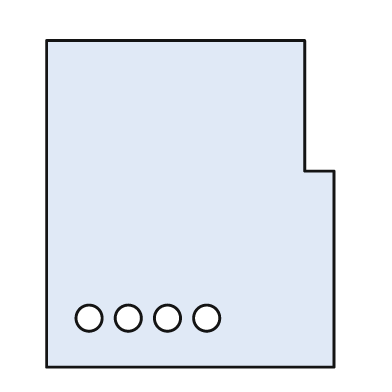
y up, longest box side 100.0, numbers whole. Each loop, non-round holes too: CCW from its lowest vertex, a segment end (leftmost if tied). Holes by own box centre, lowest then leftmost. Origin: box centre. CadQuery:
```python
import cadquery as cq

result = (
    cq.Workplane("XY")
    .moveTo(-44.0, -50.0)
    .lineTo(44.0, -50.0)
    .lineTo(44.0, 10.0)
    .lineTo(35.0, 10.0)
    .lineTo(35.0, 50.0)
    .lineTo(-44.0, 50.0)
    .close()
    .moveTo(-31.0, -35.0)
    .circle(4.0)
    .moveTo(-19.0, -35.0)
    .circle(4.0)
    .moveTo(-7.0, -35.0)
    .circle(4.0)
    .moveTo(5.0, -35.0)
    .circle(4.0)
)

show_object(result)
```